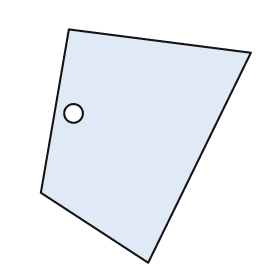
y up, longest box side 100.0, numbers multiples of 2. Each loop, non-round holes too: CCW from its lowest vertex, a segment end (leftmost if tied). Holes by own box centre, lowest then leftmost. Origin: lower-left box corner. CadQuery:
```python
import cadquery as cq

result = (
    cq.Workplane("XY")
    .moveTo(46.0, 0.0)
    .lineTo(90.0, 90.0)
    .lineTo(12.0, 100.0)
    .lineTo(0.0, 30.0)
    .close()
    .moveTo(14.0, 64.0)
    .circle(4.0)
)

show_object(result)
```